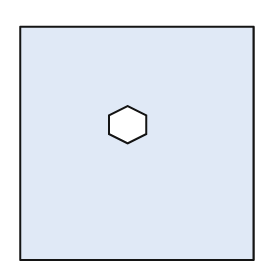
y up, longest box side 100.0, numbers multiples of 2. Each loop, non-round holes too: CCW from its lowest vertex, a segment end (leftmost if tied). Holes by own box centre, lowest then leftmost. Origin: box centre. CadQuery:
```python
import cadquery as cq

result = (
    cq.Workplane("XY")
    .moveTo(-50.0, -50.0)
    .lineTo(50.0, -50.0)
    .lineTo(50.0, 50.0)
    .lineTo(-50.0, 50.0)
    .close()
    .moveTo(-4.0, 0.0)
    .lineTo(4.0, 4.0)
    .lineTo(4.0, 12.0)
    .lineTo(-4.0, 16.0)
    .lineTo(-12.0, 12.0)
    .lineTo(-12.0, 4.0)
    .close()
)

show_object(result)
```